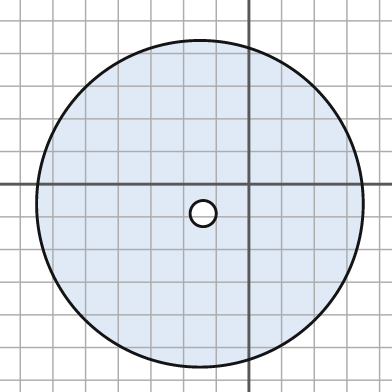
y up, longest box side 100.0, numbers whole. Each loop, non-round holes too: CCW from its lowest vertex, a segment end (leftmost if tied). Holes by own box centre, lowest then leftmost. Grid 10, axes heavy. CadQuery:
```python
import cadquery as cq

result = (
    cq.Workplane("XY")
    .moveTo(-15.0, -6.0)
    .circle(50.0)
    .moveTo(-14.0, -9.0)
    .circle(4.0)
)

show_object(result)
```